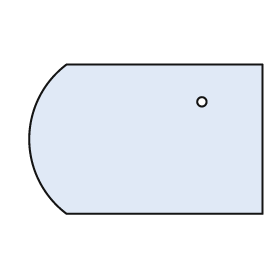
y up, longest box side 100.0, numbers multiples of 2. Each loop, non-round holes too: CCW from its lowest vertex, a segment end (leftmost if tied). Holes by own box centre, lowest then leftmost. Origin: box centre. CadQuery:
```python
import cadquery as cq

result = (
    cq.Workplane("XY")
    .moveTo(-34.0, -32.0)
    .lineTo(50.0, -32.0)
    .lineTo(50.0, 32.0)
    .lineTo(-34.0, 32.0)
    .threePointArc((-50.0, 0.0), (-34.0, -32.0))
    .close()
    .moveTo(24.0, 16.0)
    .circle(2.0)
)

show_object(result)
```